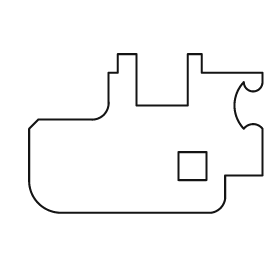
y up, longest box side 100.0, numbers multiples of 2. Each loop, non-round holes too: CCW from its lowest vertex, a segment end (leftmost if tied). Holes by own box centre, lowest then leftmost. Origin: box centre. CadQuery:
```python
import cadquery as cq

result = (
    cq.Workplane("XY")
    .moveTo(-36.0, -34.0)
    .lineTo(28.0, -34.0)
    .threePointArc((32.0, -32.0), (34.0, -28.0))
    .lineTo(34.0, -18.0)
    .lineTo(50.0, -18.0)
    .lineTo(50.0, 2.0)
    .threePointArc((46.0, 4.0), (42.0, 2.0))
    .threePointArc((38.0, 12.0), (42.0, 22.0))
    .threePointArc((46.0, 18.0), (50.0, 22.0))
    .lineTo(50.0, 26.0)
    .lineTo(24.0, 26.0)
    .lineTo(24.0, 34.0)
    .lineTo(18.0, 34.0)
    .lineTo(18.0, 12.0)
    .lineTo(-4.0, 12.0)
    .lineTo(-4.0, 34.0)
    .lineTo(-12.0, 34.0)
    .lineTo(-12.0, 26.0)
    .lineTo(-16.0, 26.0)
    .lineTo(-16.0, 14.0)
    .threePointArc((-18.0, 8.0), (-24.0, 6.0))
    .lineTo(-46.0, 6.0)
    .lineTo(-50.0, 2.0)
    .lineTo(-50.0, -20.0)
    .threePointArc((-46.0, -30.0), (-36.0, -34.0))
    .close()
    .moveTo(14.0, -20.0)
    .lineTo(26.0, -20.0)
    .lineTo(26.0, -8.0)
    .lineTo(14.0, -8.0)
    .close()
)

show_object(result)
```